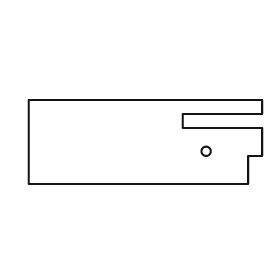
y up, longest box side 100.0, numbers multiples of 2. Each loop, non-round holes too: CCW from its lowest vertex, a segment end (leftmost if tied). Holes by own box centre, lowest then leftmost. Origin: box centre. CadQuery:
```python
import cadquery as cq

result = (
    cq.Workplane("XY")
    .moveTo(-50.0, -18.0)
    .lineTo(44.0, -18.0)
    .lineTo(44.0, -6.0)
    .lineTo(50.0, -6.0)
    .lineTo(50.0, 6.0)
    .lineTo(16.0, 6.0)
    .lineTo(16.0, 12.0)
    .lineTo(50.0, 12.0)
    .lineTo(50.0, 18.0)
    .lineTo(-50.0, 18.0)
    .close()
    .moveTo(26.0, -4.0)
    .circle(2.0)
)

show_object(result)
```